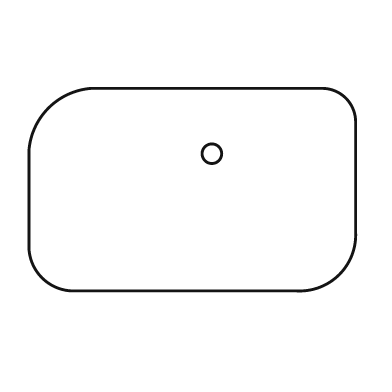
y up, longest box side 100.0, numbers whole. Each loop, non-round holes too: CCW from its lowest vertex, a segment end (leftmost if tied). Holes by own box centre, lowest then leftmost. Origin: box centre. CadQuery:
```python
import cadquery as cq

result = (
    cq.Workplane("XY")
    .moveTo(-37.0, -31.0)
    .lineTo(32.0, -31.0)
    .threePointArc((45.0, -26.0), (50.0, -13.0))
    .lineTo(50.0, 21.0)
    .threePointArc((47.0, 28.0), (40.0, 31.0))
    .lineTo(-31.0, 31.0)
    .threePointArc((-44.0, 25.0), (-50.0, 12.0))
    .lineTo(-50.0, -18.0)
    .threePointArc((-46.0, -27.0), (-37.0, -31.0))
    .close()
    .moveTo(6.0, 11.0)
    .circle(3.0)
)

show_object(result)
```